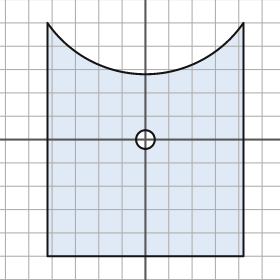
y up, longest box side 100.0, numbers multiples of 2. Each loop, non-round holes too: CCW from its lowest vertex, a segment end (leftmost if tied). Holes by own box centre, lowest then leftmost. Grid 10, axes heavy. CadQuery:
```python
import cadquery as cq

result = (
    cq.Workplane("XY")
    .moveTo(-42.0, -50.0)
    .lineTo(42.0, -50.0)
    .lineTo(42.0, 50.0)
    .threePointArc((0.0, 28.0), (-42.0, 50.0))
    .close()
    .moveTo(0.0, 0.0)
    .circle(4.0)
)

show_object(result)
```